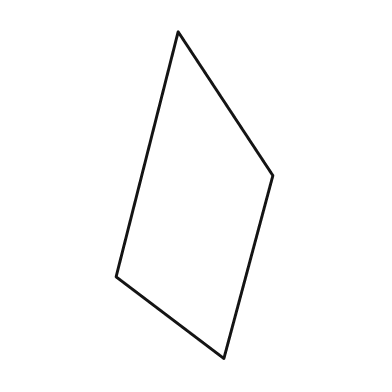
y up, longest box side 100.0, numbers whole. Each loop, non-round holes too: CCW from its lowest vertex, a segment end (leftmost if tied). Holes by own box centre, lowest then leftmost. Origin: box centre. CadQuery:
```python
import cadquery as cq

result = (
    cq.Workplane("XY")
    .moveTo(9.0, -50.0)
    .lineTo(24.0, 6.0)
    .lineTo(-5.0, 50.0)
    .lineTo(-24.0, -25.0)
    .close()
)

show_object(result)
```